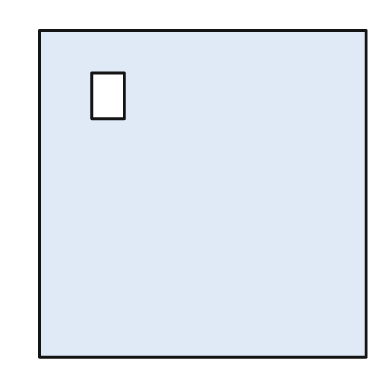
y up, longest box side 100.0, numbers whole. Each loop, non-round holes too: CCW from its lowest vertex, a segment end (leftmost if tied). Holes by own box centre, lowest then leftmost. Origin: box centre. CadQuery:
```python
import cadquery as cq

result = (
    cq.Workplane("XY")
    .moveTo(-50.0, -50.0)
    .lineTo(50.0, -50.0)
    .lineTo(50.0, 50.0)
    .lineTo(-50.0, 50.0)
    .close()
    .moveTo(-34.0, 23.0)
    .lineTo(-24.0, 23.0)
    .lineTo(-24.0, 37.0)
    .lineTo(-34.0, 37.0)
    .close()
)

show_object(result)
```